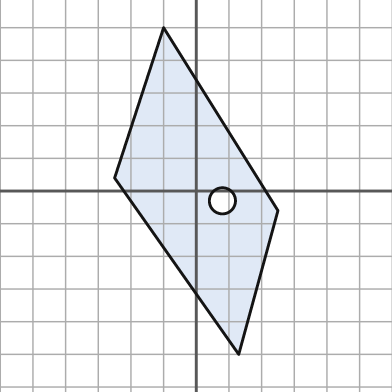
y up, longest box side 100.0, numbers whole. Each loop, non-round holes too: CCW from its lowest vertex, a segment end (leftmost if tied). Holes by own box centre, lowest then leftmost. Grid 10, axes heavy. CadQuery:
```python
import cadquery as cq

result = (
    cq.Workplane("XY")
    .moveTo(13.0, -50.0)
    .lineTo(25.0, -6.0)
    .lineTo(-10.0, 50.0)
    .lineTo(-25.0, 4.0)
    .close()
    .moveTo(8.0, -3.0)
    .circle(4.0)
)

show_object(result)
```